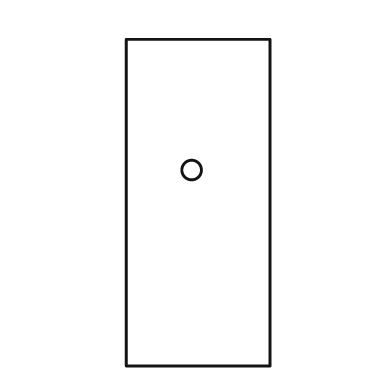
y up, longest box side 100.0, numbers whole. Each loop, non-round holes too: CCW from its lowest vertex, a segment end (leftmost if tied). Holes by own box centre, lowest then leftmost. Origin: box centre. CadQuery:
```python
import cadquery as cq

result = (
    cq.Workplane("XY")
    .moveTo(-22.0, -50.0)
    .lineTo(22.0, -50.0)
    .lineTo(22.0, 50.0)
    .lineTo(-22.0, 50.0)
    .close()
    .moveTo(-2.0, 10.0)
    .circle(3.0)
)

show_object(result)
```